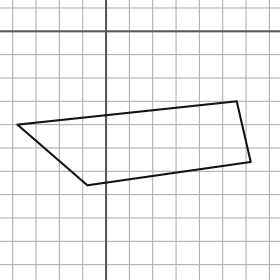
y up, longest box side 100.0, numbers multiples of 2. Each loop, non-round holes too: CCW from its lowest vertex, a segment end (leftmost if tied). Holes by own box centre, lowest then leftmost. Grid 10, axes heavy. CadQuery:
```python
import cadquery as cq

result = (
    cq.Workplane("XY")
    .moveTo(-8.0, -66.0)
    .lineTo(62.0, -56.0)
    .lineTo(56.0, -30.0)
    .lineTo(-38.0, -40.0)
    .close()
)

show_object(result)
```